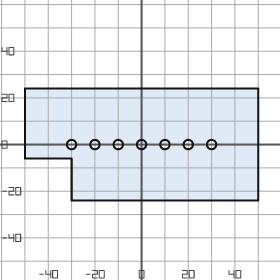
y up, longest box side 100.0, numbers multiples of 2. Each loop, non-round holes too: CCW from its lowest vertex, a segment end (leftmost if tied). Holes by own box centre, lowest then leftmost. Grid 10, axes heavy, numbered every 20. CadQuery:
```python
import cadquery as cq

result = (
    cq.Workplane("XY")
    .moveTo(-30.0, -24.0)
    .lineTo(50.0, -24.0)
    .lineTo(50.0, 24.0)
    .lineTo(-50.0, 24.0)
    .lineTo(-50.0, -6.0)
    .lineTo(-30.0, -6.0)
    .close()
    .moveTo(-30.0, 0.0)
    .circle(2.0)
    .moveTo(-20.0, 0.0)
    .circle(2.0)
    .moveTo(-10.0, 0.0)
    .circle(2.0)
    .moveTo(0.0, 0.0)
    .circle(2.0)
    .moveTo(10.0, 0.0)
    .circle(2.0)
    .moveTo(20.0, 0.0)
    .circle(2.0)
    .moveTo(30.0, 0.0)
    .circle(2.0)
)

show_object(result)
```